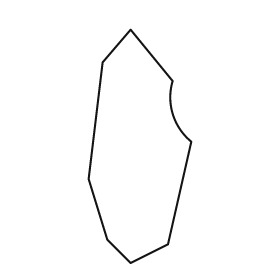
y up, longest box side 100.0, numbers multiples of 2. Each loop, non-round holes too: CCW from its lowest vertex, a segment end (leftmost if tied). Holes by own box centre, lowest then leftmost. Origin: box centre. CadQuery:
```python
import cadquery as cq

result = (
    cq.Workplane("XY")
    .moveTo(-4.0, -50.0)
    .lineTo(12.0, -42.0)
    .lineTo(22.0, 2.0)
    .threePointArc((14.0, 14.0), (14.0, 28.0))
    .lineTo(-4.0, 50.0)
    .lineTo(-16.0, 36.0)
    .lineTo(-22.0, -14.0)
    .lineTo(-14.0, -40.0)
    .close()
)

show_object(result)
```